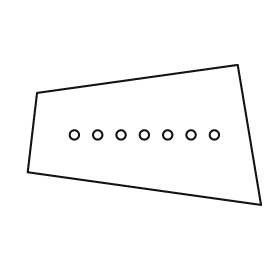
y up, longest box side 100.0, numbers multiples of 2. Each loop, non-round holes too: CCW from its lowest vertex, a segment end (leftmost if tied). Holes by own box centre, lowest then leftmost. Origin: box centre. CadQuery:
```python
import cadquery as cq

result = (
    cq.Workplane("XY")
    .moveTo(50.0, -30.0)
    .lineTo(40.0, 30.0)
    .lineTo(-46.0, 18.0)
    .lineTo(-50.0, -16.0)
    .close()
    .moveTo(-30.0, 0.0)
    .circle(2.0)
    .moveTo(-20.0, 0.0)
    .circle(2.0)
    .moveTo(-10.0, 0.0)
    .circle(2.0)
    .moveTo(0.0, 0.0)
    .circle(2.0)
    .moveTo(10.0, 0.0)
    .circle(2.0)
    .moveTo(20.0, 0.0)
    .circle(2.0)
    .moveTo(30.0, 0.0)
    .circle(2.0)
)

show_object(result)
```